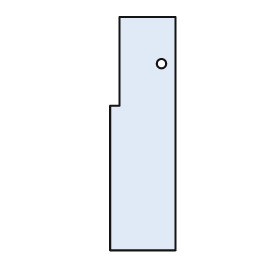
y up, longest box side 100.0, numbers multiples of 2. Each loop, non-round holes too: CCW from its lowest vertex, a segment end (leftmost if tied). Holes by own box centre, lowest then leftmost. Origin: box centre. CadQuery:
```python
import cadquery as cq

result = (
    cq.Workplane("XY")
    .moveTo(-14.0, -50.0)
    .lineTo(14.0, -50.0)
    .lineTo(14.0, 50.0)
    .lineTo(-10.0, 50.0)
    .lineTo(-10.0, 12.0)
    .lineTo(-14.0, 12.0)
    .close()
    .moveTo(8.0, 30.0)
    .circle(2.0)
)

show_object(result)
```